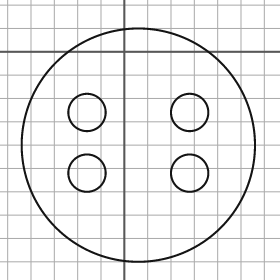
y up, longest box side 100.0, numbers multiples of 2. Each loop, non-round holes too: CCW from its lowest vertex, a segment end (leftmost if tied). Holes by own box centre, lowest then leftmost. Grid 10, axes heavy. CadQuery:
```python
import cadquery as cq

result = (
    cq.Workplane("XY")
    .moveTo(6.0, -40.0)
    .circle(50.0)
    .moveTo(-16.0, -52.0)
    .circle(8.0)
    .moveTo(28.0, -52.0)
    .circle(8.0)
    .moveTo(-16.0, -26.0)
    .circle(8.0)
    .moveTo(28.0, -26.0)
    .circle(8.0)
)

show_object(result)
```